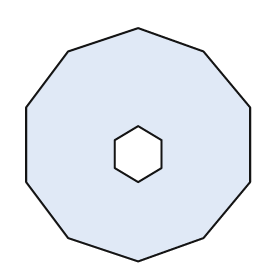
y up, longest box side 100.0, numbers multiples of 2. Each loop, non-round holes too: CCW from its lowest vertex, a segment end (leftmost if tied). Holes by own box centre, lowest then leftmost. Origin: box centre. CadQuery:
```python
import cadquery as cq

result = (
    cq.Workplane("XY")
    .moveTo(0.0, -50.0)
    .lineTo(28.0, -40.0)
    .lineTo(48.0, -16.0)
    .lineTo(48.0, 16.0)
    .lineTo(28.0, 40.0)
    .lineTo(0.0, 50.0)
    .lineTo(-30.0, 40.0)
    .lineTo(-48.0, 16.0)
    .lineTo(-48.0, -16.0)
    .lineTo(-30.0, -40.0)
    .close()
    .moveTo(0.0, -16.0)
    .lineTo(10.0, -10.0)
    .lineTo(10.0, 2.0)
    .lineTo(0.0, 8.0)
    .lineTo(-10.0, 2.0)
    .lineTo(-10.0, -10.0)
    .close()
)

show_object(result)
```